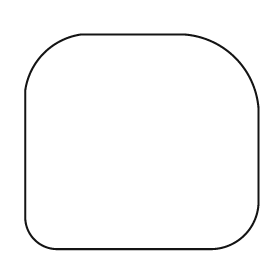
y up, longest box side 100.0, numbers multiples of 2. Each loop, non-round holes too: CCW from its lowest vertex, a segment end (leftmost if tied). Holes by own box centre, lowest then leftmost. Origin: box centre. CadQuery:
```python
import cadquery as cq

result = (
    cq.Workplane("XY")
    .moveTo(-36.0, -46.0)
    .lineTo(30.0, -46.0)
    .threePointArc((44.0, -40.0), (50.0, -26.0))
    .lineTo(50.0, 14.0)
    .threePointArc((40.0, 36.0), (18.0, 46.0))
    .lineTo(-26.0, 46.0)
    .threePointArc((-42.0, 38.0), (-50.0, 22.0))
    .lineTo(-50.0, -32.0)
    .threePointArc((-46.0, -42.0), (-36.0, -46.0))
    .close()
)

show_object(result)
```